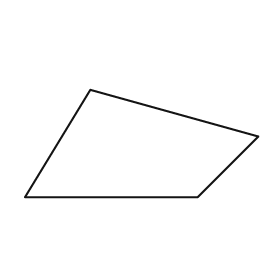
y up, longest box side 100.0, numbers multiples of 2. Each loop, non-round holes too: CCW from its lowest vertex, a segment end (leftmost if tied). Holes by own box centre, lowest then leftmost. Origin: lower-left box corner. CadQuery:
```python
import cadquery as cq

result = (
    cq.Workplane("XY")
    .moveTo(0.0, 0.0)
    .lineTo(74.0, 0.0)
    .lineTo(100.0, 26.0)
    .lineTo(28.0, 46.0)
    .close()
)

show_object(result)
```